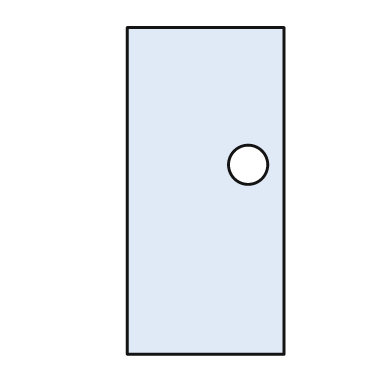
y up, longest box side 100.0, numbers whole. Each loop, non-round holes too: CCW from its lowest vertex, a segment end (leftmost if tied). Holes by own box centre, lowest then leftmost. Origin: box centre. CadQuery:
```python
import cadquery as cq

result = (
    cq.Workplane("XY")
    .moveTo(-24.0, -50.0)
    .lineTo(24.0, -50.0)
    .lineTo(24.0, 50.0)
    .lineTo(-24.0, 50.0)
    .close()
    .moveTo(13.0, 8.0)
    .circle(6.0)
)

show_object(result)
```